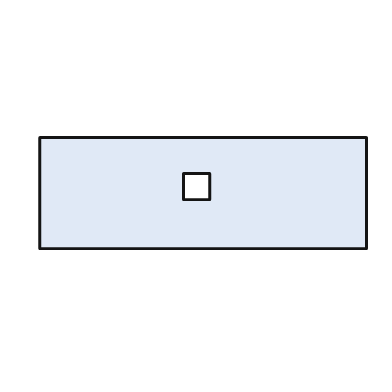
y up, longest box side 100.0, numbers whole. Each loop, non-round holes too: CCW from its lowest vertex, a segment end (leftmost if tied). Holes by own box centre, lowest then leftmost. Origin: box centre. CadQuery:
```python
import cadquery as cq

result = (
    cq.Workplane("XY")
    .moveTo(-50.0, -17.0)
    .lineTo(50.0, -17.0)
    .lineTo(50.0, 17.0)
    .lineTo(-50.0, 17.0)
    .close()
    .moveTo(-6.0, -2.0)
    .lineTo(2.0, -2.0)
    .lineTo(2.0, 6.0)
    .lineTo(-6.0, 6.0)
    .close()
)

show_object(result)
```